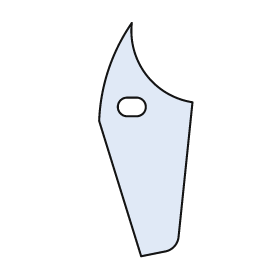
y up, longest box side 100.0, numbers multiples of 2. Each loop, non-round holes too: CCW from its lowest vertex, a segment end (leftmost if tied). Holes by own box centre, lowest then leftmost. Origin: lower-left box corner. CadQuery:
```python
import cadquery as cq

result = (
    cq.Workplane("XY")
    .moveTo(18.0, 0.0)
    .lineTo(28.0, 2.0)
    .threePointArc((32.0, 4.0), (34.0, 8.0))
    .lineTo(40.0, 66.0)
    .threePointArc((20.0, 78.0), (14.0, 100.0))
    .threePointArc((4.0, 80.0), (0.0, 58.0))
    .close()
    .moveTo(12.0, 60.0)
    .lineTo(16.0, 60.0)
    .threePointArc((20.0, 64.0), (16.0, 68.0))
    .lineTo(12.0, 68.0)
    .threePointArc((8.0, 64.0), (12.0, 60.0))
    .close()
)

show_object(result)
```